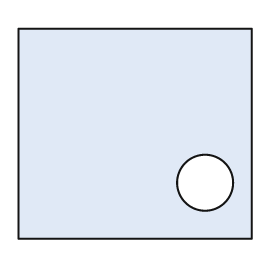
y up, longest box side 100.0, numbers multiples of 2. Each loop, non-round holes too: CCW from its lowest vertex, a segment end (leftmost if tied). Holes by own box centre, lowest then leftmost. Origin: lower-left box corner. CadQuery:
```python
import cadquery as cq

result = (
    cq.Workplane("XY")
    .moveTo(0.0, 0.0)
    .lineTo(100.0, 0.0)
    .lineTo(100.0, 90.0)
    .lineTo(0.0, 90.0)
    .close()
    .moveTo(80.0, 24.0)
    .circle(12.0)
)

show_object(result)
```